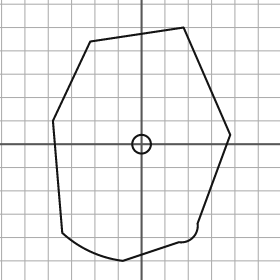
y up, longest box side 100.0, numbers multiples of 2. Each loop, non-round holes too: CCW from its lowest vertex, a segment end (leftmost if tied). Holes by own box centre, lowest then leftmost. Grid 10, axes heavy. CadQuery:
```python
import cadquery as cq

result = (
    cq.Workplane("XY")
    .moveTo(-8.0, -50.0)
    .lineTo(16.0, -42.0)
    .threePointArc((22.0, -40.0), (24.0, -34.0))
    .lineTo(38.0, 4.0)
    .lineTo(18.0, 50.0)
    .lineTo(-22.0, 44.0)
    .lineTo(-38.0, 10.0)
    .lineTo(-34.0, -38.0)
    .threePointArc((-22.0, -46.0), (-8.0, -50.0))
    .close()
    .moveTo(0.0, 0.0)
    .circle(4.0)
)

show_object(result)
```